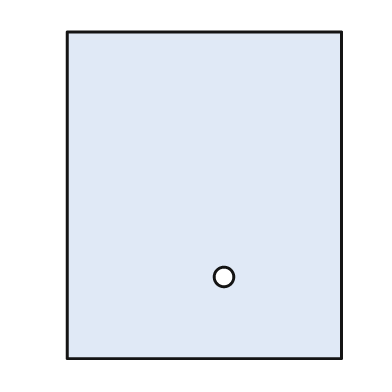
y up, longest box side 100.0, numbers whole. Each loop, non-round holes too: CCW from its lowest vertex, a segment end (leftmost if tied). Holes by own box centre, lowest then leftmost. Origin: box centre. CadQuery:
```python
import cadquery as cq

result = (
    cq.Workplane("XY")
    .moveTo(-42.0, -50.0)
    .lineTo(42.0, -50.0)
    .lineTo(42.0, 50.0)
    .lineTo(-42.0, 50.0)
    .close()
    .moveTo(6.0, -25.0)
    .circle(3.0)
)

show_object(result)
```